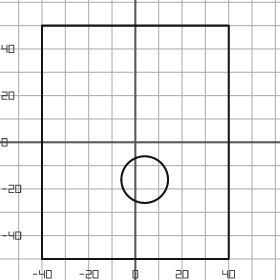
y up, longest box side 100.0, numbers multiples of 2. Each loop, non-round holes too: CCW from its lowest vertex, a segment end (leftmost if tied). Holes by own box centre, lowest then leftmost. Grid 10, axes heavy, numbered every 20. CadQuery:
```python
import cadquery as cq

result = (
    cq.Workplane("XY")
    .moveTo(-40.0, -50.0)
    .lineTo(40.0, -50.0)
    .lineTo(40.0, 50.0)
    .lineTo(-40.0, 50.0)
    .close()
    .moveTo(4.0, -16.0)
    .circle(10.0)
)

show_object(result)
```